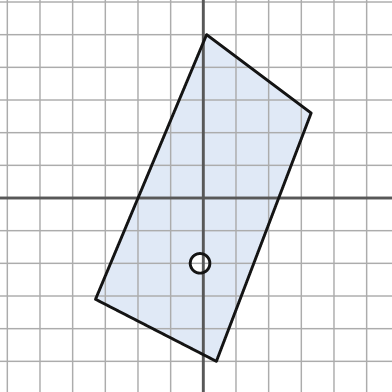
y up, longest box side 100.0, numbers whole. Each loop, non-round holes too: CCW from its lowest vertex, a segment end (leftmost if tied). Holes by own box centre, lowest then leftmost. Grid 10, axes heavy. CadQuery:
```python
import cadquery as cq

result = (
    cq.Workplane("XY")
    .moveTo(4.0, -50.0)
    .lineTo(33.0, 26.0)
    .lineTo(1.0, 50.0)
    .lineTo(-33.0, -31.0)
    .close()
    .moveTo(-1.0, -20.0)
    .circle(3.0)
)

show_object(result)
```